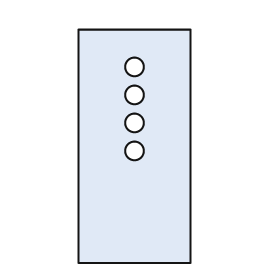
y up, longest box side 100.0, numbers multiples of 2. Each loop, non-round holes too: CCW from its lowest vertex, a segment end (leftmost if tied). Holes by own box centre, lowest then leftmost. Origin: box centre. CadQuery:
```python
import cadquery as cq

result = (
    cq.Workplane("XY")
    .moveTo(-24.0, -50.0)
    .lineTo(24.0, -50.0)
    .lineTo(24.0, 50.0)
    .lineTo(-24.0, 50.0)
    .close()
    .moveTo(0.0, -2.0)
    .circle(4.0)
    .moveTo(0.0, 10.0)
    .circle(4.0)
    .moveTo(0.0, 22.0)
    .circle(4.0)
    .moveTo(0.0, 34.0)
    .circle(4.0)
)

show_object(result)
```